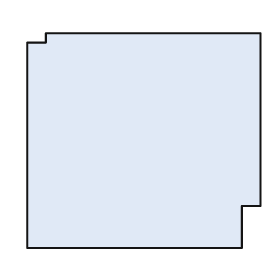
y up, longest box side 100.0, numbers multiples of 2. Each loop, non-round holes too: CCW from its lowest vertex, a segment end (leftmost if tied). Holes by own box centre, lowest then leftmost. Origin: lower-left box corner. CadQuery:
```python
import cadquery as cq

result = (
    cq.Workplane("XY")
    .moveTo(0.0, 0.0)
    .lineTo(92.0, 0.0)
    .lineTo(92.0, 18.0)
    .lineTo(100.0, 18.0)
    .lineTo(100.0, 92.0)
    .lineTo(8.0, 92.0)
    .lineTo(8.0, 88.0)
    .lineTo(0.0, 88.0)
    .close()
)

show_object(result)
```